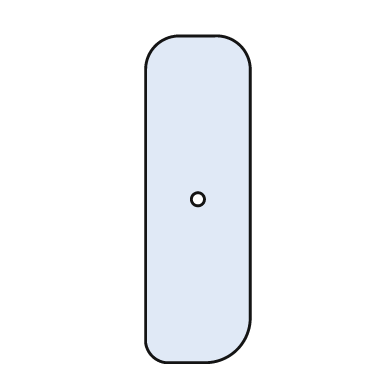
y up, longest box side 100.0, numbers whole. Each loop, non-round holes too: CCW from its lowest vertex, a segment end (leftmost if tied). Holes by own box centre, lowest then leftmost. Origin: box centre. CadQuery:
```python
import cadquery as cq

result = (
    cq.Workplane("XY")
    .moveTo(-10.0, -50.0)
    .lineTo(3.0, -50.0)
    .threePointArc((12.0, -46.0), (16.0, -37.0))
    .lineTo(16.0, 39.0)
    .threePointArc((13.0, 47.0), (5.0, 50.0))
    .lineTo(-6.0, 50.0)
    .threePointArc((-13.0, 47.0), (-16.0, 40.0))
    .lineTo(-16.0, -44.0)
    .threePointArc((-14.0, -48.0), (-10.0, -50.0))
    .close()
    .moveTo(0.0, 0.0)
    .circle(2.0)
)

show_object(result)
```